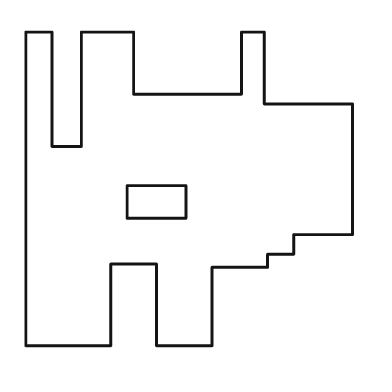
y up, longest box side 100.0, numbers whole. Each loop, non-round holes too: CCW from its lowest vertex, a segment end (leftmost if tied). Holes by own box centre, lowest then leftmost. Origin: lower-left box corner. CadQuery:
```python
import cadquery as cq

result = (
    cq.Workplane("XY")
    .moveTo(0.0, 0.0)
    .lineTo(26.0, 0.0)
    .lineTo(26.0, 25.0)
    .lineTo(40.0, 25.0)
    .lineTo(40.0, 0.0)
    .lineTo(57.0, 0.0)
    .lineTo(57.0, 24.0)
    .lineTo(74.0, 24.0)
    .lineTo(74.0, 28.0)
    .lineTo(82.0, 28.0)
    .lineTo(82.0, 34.0)
    .lineTo(100.0, 34.0)
    .lineTo(100.0, 74.0)
    .lineTo(73.0, 74.0)
    .lineTo(73.0, 96.0)
    .lineTo(66.0, 96.0)
    .lineTo(66.0, 77.0)
    .lineTo(33.0, 77.0)
    .lineTo(33.0, 96.0)
    .lineTo(17.0, 96.0)
    .lineTo(17.0, 61.0)
    .lineTo(8.0, 61.0)
    .lineTo(8.0, 96.0)
    .lineTo(0.0, 96.0)
    .close()
    .moveTo(31.0, 39.0)
    .lineTo(49.0, 39.0)
    .lineTo(49.0, 49.0)
    .lineTo(31.0, 49.0)
    .close()
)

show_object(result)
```